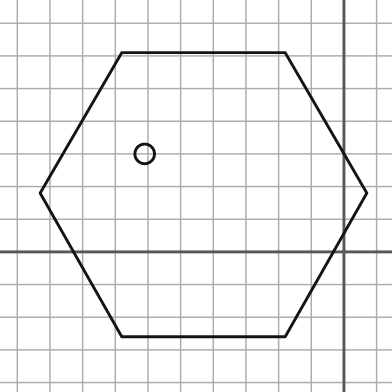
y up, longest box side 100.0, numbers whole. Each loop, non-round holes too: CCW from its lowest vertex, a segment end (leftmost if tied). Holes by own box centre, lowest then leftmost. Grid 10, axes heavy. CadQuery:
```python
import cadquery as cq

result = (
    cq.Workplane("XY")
    .moveTo(-68.0, -26.0)
    .lineTo(-18.0, -26.0)
    .lineTo(7.0, 18.0)
    .lineTo(-18.0, 61.0)
    .lineTo(-68.0, 61.0)
    .lineTo(-93.0, 18.0)
    .close()
    .moveTo(-61.0, 30.0)
    .circle(3.0)
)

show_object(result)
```